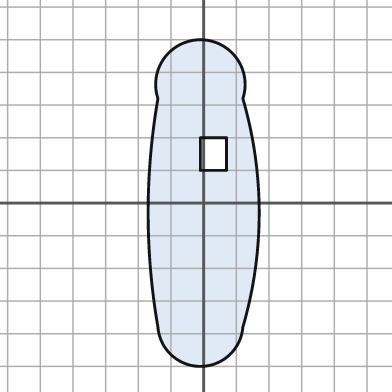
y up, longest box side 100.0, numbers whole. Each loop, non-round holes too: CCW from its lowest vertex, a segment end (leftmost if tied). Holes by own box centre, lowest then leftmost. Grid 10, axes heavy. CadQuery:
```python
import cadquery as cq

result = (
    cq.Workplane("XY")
    .moveTo(-14.0, -38.0)
    .threePointArc((-1.0, -50.0), (12.0, -38.0))
    .threePointArc((17.0, -3.0), (12.0, 32.0))
    .threePointArc((-1.0, 50.0), (-14.0, 32.0))
    .threePointArc((-17.0, -3.0), (-14.0, -38.0))
    .close()
    .moveTo(-1.0, 10.0)
    .lineTo(7.0, 10.0)
    .lineTo(7.0, 20.0)
    .lineTo(-1.0, 20.0)
    .close()
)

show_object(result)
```